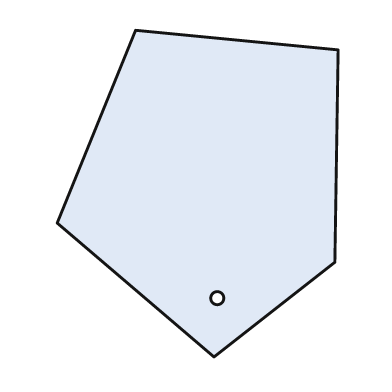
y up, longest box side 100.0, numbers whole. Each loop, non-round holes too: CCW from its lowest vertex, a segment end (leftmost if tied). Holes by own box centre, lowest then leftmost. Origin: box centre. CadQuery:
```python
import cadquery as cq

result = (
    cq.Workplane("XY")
    .moveTo(5.0, -50.0)
    .lineTo(42.0, -21.0)
    .lineTo(43.0, 44.0)
    .lineTo(-19.0, 50.0)
    .lineTo(-43.0, -9.0)
    .close()
    .moveTo(6.0, -32.0)
    .circle(2.0)
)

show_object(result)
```